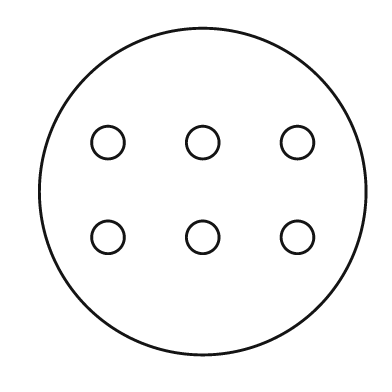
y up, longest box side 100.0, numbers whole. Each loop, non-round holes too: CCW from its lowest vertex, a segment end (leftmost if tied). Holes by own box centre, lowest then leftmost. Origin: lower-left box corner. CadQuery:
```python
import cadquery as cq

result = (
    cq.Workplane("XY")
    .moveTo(50.0, 50.0)
    .circle(50.0)
    .moveTo(21.0, 36.0)
    .circle(5.0)
    .moveTo(50.0, 36.0)
    .circle(5.0)
    .moveTo(79.0, 36.0)
    .circle(5.0)
    .moveTo(21.0, 65.0)
    .circle(5.0)
    .moveTo(50.0, 65.0)
    .circle(5.0)
    .moveTo(79.0, 65.0)
    .circle(5.0)
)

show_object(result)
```